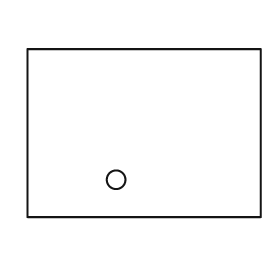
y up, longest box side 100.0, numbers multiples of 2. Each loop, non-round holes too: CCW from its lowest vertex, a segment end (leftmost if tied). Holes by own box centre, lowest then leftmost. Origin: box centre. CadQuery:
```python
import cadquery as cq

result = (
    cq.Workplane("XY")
    .moveTo(-50.0, -36.0)
    .lineTo(50.0, -36.0)
    .lineTo(50.0, 36.0)
    .lineTo(-50.0, 36.0)
    .close()
    .moveTo(-12.0, -20.0)
    .circle(4.0)
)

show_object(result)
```